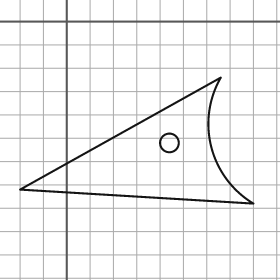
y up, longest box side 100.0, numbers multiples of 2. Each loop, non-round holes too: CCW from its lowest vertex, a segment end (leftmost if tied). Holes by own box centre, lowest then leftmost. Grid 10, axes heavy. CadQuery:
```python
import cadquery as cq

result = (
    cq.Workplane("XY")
    .moveTo(80.0, -78.0)
    .threePointArc((62.0, -54.0), (66.0, -24.0))
    .lineTo(-20.0, -72.0)
    .close()
    .moveTo(44.0, -52.0)
    .circle(4.0)
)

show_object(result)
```